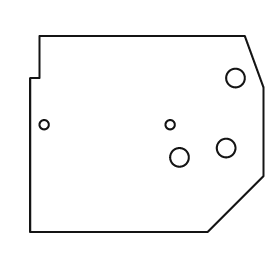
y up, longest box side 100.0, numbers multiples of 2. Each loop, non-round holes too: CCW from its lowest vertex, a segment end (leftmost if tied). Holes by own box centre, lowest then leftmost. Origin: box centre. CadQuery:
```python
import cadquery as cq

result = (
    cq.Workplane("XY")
    .moveTo(-50.0, -42.0)
    .lineTo(26.0, -42.0)
    .lineTo(50.0, -18.0)
    .lineTo(50.0, 20.0)
    .lineTo(42.0, 42.0)
    .lineTo(-46.0, 42.0)
    .lineTo(-46.0, 24.0)
    .lineTo(-50.0, 24.0)
    .close()
    .moveTo(14.0, -10.0)
    .circle(4.0)
    .moveTo(34.0, -6.0)
    .circle(4.0)
    .moveTo(-44.0, 4.0)
    .circle(2.0)
    .moveTo(10.0, 4.0)
    .circle(2.0)
    .moveTo(38.0, 24.0)
    .circle(4.0)
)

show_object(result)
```